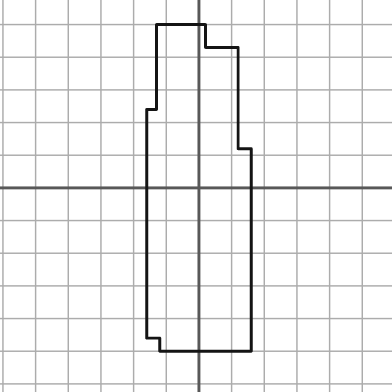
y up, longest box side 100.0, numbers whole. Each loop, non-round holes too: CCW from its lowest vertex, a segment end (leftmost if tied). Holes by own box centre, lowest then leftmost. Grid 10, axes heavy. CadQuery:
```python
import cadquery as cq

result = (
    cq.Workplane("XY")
    .moveTo(-12.0, -50.0)
    .lineTo(16.0, -50.0)
    .lineTo(16.0, 12.0)
    .lineTo(12.0, 12.0)
    .lineTo(12.0, 43.0)
    .lineTo(2.0, 43.0)
    .lineTo(2.0, 50.0)
    .lineTo(-13.0, 50.0)
    .lineTo(-13.0, 24.0)
    .lineTo(-16.0, 24.0)
    .lineTo(-16.0, -46.0)
    .lineTo(-12.0, -46.0)
    .close()
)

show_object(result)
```